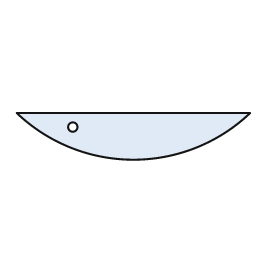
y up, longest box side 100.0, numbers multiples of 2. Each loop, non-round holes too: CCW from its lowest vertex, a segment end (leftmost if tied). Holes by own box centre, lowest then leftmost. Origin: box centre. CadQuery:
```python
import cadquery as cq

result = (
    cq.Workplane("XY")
    .moveTo(-50.0, 10.0)
    .threePointArc((0.0, -10.0), (50.0, 10.0))
    .close()
    .moveTo(-26.0, 4.0)
    .circle(2.0)
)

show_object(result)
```